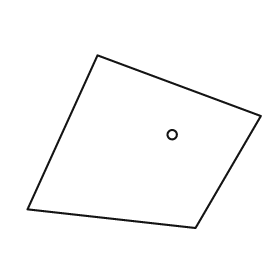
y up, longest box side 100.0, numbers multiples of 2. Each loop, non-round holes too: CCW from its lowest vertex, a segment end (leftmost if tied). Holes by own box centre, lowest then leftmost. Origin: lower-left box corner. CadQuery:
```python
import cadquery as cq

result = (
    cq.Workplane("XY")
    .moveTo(72.0, 0.0)
    .lineTo(100.0, 48.0)
    .lineTo(30.0, 74.0)
    .lineTo(0.0, 8.0)
    .close()
    .moveTo(62.0, 40.0)
    .circle(2.0)
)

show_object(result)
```